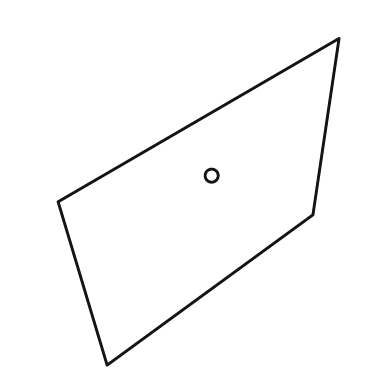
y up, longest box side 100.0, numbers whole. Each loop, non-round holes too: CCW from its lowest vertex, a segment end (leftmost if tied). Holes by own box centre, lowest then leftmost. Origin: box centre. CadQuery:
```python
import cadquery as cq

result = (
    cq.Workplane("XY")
    .moveTo(-28.0, -50.0)
    .lineTo(35.0, -4.0)
    .lineTo(43.0, 50.0)
    .lineTo(-43.0, 0.0)
    .close()
    .moveTo(4.0, 8.0)
    .circle(2.0)
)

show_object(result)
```